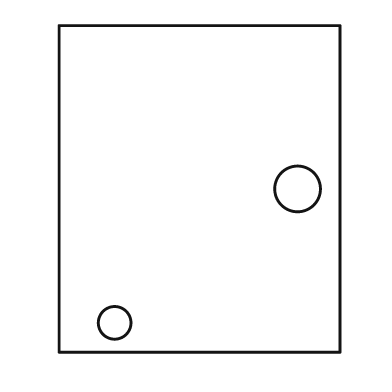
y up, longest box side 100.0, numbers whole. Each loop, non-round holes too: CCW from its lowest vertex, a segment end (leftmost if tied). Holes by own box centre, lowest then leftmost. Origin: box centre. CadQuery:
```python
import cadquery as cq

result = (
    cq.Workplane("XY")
    .moveTo(-43.0, -50.0)
    .lineTo(43.0, -50.0)
    .lineTo(43.0, 50.0)
    .lineTo(-43.0, 50.0)
    .close()
    .moveTo(-26.0, -41.0)
    .circle(5.0)
    .moveTo(30.0, 0.0)
    .circle(7.0)
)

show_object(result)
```